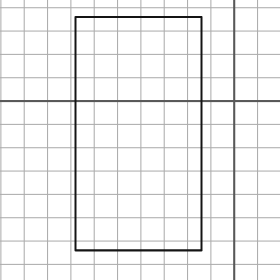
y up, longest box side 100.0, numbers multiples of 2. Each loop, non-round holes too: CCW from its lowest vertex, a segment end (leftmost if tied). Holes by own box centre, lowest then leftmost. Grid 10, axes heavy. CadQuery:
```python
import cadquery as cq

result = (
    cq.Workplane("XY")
    .moveTo(-68.0, -64.0)
    .lineTo(-14.0, -64.0)
    .lineTo(-14.0, 36.0)
    .lineTo(-68.0, 36.0)
    .close()
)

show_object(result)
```